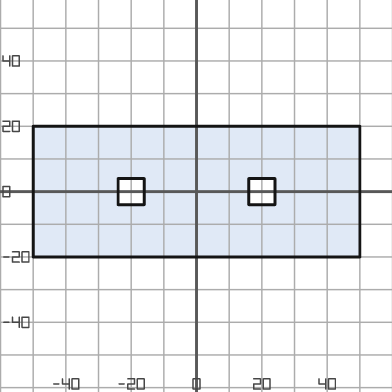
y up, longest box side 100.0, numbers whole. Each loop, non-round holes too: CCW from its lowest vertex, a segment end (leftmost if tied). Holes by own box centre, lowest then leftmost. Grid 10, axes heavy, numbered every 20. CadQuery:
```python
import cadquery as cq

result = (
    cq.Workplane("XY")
    .moveTo(-50.0, -20.0)
    .lineTo(50.0, -20.0)
    .lineTo(50.0, 20.0)
    .lineTo(-50.0, 20.0)
    .close()
    .moveTo(-24.0, -4.0)
    .lineTo(-16.0, -4.0)
    .lineTo(-16.0, 4.0)
    .lineTo(-24.0, 4.0)
    .close()
    .moveTo(16.0, -4.0)
    .lineTo(24.0, -4.0)
    .lineTo(24.0, 4.0)
    .lineTo(16.0, 4.0)
    .close()
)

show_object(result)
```